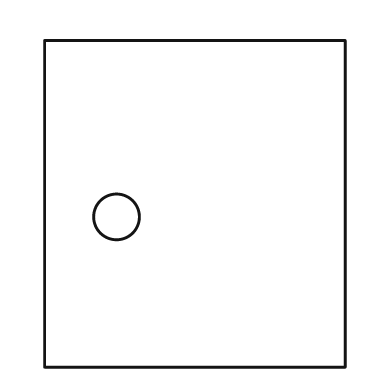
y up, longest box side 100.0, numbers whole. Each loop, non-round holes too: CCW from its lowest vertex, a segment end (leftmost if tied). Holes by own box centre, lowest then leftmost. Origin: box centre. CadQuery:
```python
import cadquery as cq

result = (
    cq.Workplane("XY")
    .moveTo(-46.0, -50.0)
    .lineTo(46.0, -50.0)
    .lineTo(46.0, 50.0)
    .lineTo(-46.0, 50.0)
    .close()
    .moveTo(-24.0, -4.0)
    .circle(7.0)
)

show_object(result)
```